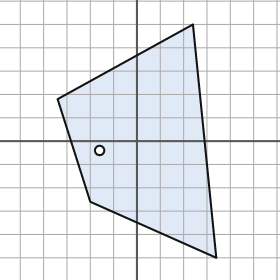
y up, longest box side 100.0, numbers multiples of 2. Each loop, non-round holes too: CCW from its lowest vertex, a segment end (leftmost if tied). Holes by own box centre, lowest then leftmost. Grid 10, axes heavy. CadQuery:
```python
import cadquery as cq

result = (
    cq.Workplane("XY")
    .moveTo(34.0, -50.0)
    .lineTo(24.0, 50.0)
    .lineTo(-34.0, 18.0)
    .lineTo(-20.0, -26.0)
    .close()
    .moveTo(-16.0, -4.0)
    .circle(2.0)
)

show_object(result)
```